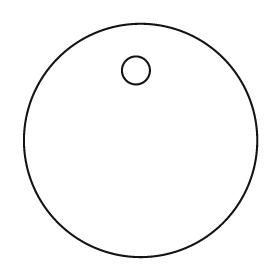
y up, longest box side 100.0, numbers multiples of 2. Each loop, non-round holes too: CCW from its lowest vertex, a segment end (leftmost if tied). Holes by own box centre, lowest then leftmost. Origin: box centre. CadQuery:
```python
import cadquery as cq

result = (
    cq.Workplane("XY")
    .moveTo(0.0, 0.0)
    .circle(50.0)
    .moveTo(-2.0, 30.0)
    .circle(6.0)
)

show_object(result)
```